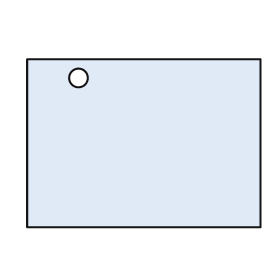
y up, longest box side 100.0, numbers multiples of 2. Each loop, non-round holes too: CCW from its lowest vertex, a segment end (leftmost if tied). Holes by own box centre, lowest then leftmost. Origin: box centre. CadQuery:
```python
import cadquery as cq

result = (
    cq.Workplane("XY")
    .moveTo(-50.0, -36.0)
    .lineTo(50.0, -36.0)
    .lineTo(50.0, 36.0)
    .lineTo(-50.0, 36.0)
    .close()
    .moveTo(-28.0, 28.0)
    .circle(4.0)
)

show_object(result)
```